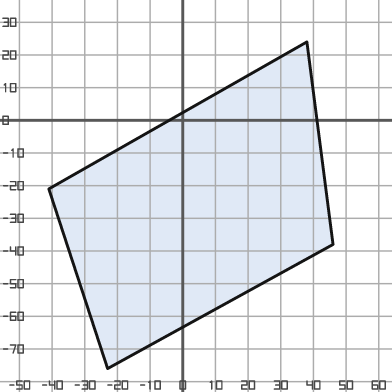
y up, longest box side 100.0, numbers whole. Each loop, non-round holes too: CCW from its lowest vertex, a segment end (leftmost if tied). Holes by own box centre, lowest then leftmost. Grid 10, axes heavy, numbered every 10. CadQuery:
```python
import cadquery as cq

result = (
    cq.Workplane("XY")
    .moveTo(-23.0, -76.0)
    .lineTo(46.0, -38.0)
    .lineTo(38.0, 24.0)
    .lineTo(-41.0, -21.0)
    .close()
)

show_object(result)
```